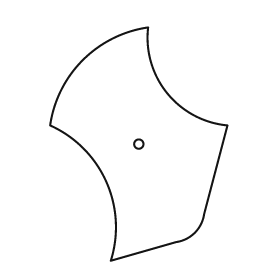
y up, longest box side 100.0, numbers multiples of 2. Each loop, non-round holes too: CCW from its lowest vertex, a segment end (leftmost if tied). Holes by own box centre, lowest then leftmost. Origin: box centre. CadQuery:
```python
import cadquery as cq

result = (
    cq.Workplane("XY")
    .moveTo(-12.0, -50.0)
    .lineTo(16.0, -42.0)
    .threePointArc((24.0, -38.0), (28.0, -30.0))
    .lineTo(38.0, 8.0)
    .threePointArc((12.0, 22.0), (4.0, 50.0))
    .threePointArc((-24.0, 36.0), (-38.0, 8.0))
    .threePointArc((-14.0, -16.0), (-12.0, -50.0))
    .close()
    .moveTo(0.0, 0.0)
    .circle(2.0)
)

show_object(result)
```